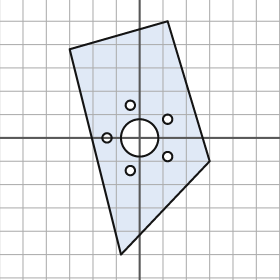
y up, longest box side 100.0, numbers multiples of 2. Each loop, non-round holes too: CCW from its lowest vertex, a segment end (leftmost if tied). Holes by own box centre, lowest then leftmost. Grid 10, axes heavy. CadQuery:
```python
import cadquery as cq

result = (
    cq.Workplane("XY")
    .moveTo(-8.0, -50.0)
    .lineTo(30.0, -10.0)
    .lineTo(12.0, 50.0)
    .lineTo(-30.0, 38.0)
    .close()
    .moveTo(-4.0, -14.0)
    .circle(2.0)
    .moveTo(12.0, -8.0)
    .circle(2.0)
    .moveTo(-14.0, 0.0)
    .circle(2.0)
    .moveTo(0.0, 0.0)
    .circle(8.0)
    .moveTo(12.0, 8.0)
    .circle(2.0)
    .moveTo(-4.0, 14.0)
    .circle(2.0)
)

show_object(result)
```